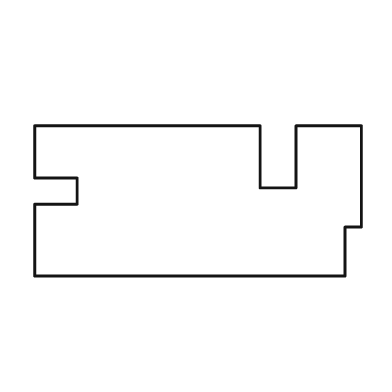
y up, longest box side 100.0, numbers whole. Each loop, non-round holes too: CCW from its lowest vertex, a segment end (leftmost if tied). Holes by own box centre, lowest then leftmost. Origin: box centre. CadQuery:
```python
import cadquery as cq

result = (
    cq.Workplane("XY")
    .moveTo(-50.0, -23.0)
    .lineTo(45.0, -23.0)
    .lineTo(45.0, -8.0)
    .lineTo(50.0, -8.0)
    .lineTo(50.0, 23.0)
    .lineTo(30.0, 23.0)
    .lineTo(30.0, 4.0)
    .lineTo(19.0, 4.0)
    .lineTo(19.0, 23.0)
    .lineTo(-50.0, 23.0)
    .lineTo(-50.0, 7.0)
    .lineTo(-37.0, 7.0)
    .lineTo(-37.0, -1.0)
    .lineTo(-50.0, -1.0)
    .close()
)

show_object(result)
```